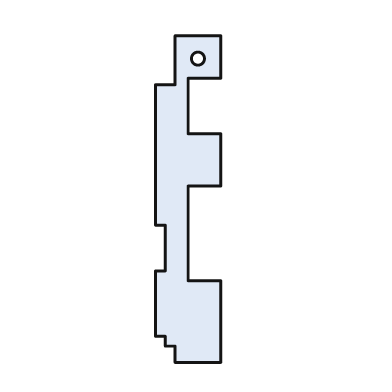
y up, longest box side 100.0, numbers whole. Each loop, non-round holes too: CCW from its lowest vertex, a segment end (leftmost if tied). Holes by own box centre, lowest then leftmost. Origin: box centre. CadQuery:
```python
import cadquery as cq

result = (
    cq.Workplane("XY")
    .moveTo(-4.0, -50.0)
    .lineTo(10.0, -50.0)
    .lineTo(10.0, -25.0)
    .lineTo(0.0, -25.0)
    .lineTo(0.0, 4.0)
    .lineTo(10.0, 4.0)
    .lineTo(10.0, 20.0)
    .lineTo(0.0, 20.0)
    .lineTo(0.0, 37.0)
    .lineTo(10.0, 37.0)
    .lineTo(10.0, 50.0)
    .lineTo(-4.0, 50.0)
    .lineTo(-4.0, 35.0)
    .lineTo(-10.0, 35.0)
    .lineTo(-10.0, -8.0)
    .lineTo(-7.0, -8.0)
    .lineTo(-7.0, -22.0)
    .lineTo(-10.0, -22.0)
    .lineTo(-10.0, -42.0)
    .lineTo(-7.0, -42.0)
    .lineTo(-7.0, -45.0)
    .lineTo(-4.0, -45.0)
    .close()
    .moveTo(3.0, 43.0)
    .circle(2.0)
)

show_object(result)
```